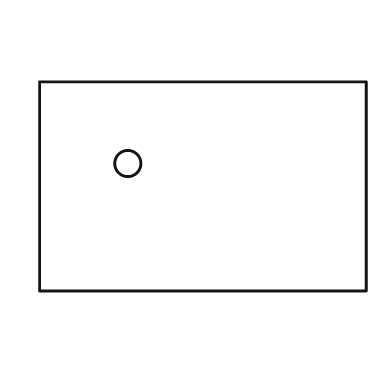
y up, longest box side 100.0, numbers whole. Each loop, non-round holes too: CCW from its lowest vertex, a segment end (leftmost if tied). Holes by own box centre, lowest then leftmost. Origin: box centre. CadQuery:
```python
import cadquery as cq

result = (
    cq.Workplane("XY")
    .moveTo(-50.0, -32.0)
    .lineTo(50.0, -32.0)
    .lineTo(50.0, 32.0)
    .lineTo(-50.0, 32.0)
    .close()
    .moveTo(-23.0, 7.0)
    .circle(4.0)
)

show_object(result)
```